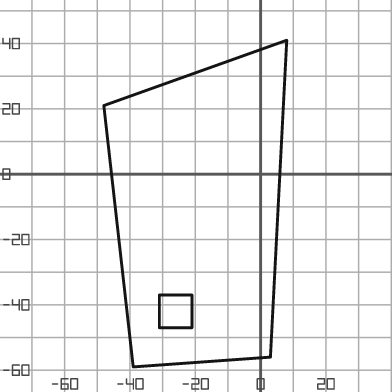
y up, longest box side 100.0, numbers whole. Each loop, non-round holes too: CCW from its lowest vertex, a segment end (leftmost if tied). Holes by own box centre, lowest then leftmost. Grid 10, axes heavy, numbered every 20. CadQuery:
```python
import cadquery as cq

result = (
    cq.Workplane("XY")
    .moveTo(-39.0, -59.0)
    .lineTo(3.0, -56.0)
    .lineTo(8.0, 41.0)
    .lineTo(-48.0, 21.0)
    .close()
    .moveTo(-31.0, -47.0)
    .lineTo(-21.0, -47.0)
    .lineTo(-21.0, -37.0)
    .lineTo(-31.0, -37.0)
    .close()
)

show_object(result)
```